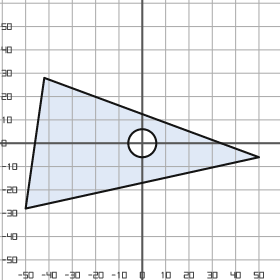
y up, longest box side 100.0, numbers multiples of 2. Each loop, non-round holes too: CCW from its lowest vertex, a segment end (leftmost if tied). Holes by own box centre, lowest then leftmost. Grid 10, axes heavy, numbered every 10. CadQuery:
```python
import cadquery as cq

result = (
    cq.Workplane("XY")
    .moveTo(-50.0, -28.0)
    .lineTo(50.0, -6.0)
    .lineTo(-42.0, 28.0)
    .close()
    .moveTo(0.0, 0.0)
    .circle(6.0)
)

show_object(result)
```